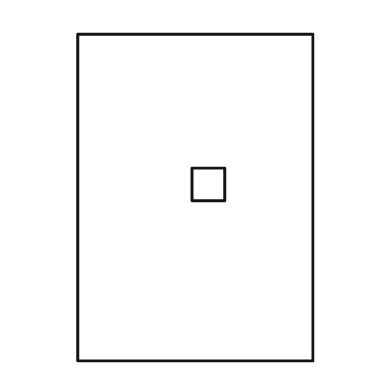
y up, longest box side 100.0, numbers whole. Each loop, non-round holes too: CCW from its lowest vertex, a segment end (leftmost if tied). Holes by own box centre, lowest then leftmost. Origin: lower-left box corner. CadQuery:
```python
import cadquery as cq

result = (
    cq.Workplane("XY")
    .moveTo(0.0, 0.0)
    .lineTo(72.0, 0.0)
    .lineTo(72.0, 100.0)
    .lineTo(0.0, 100.0)
    .close()
    .moveTo(35.0, 49.0)
    .lineTo(45.0, 49.0)
    .lineTo(45.0, 59.0)
    .lineTo(35.0, 59.0)
    .close()
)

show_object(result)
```